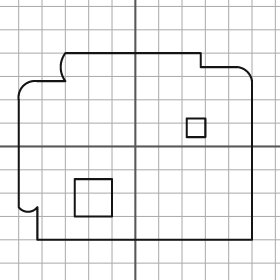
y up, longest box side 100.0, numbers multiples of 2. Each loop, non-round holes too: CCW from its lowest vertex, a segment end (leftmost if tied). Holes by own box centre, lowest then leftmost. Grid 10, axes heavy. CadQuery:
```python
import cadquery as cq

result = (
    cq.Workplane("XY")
    .moveTo(-42.0, -40.0)
    .lineTo(50.0, -40.0)
    .lineTo(50.0, 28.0)
    .threePointArc((48.0, 32.0), (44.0, 34.0))
    .lineTo(28.0, 34.0)
    .lineTo(28.0, 40.0)
    .lineTo(-30.0, 40.0)
    .threePointArc((-32.0, 34.0), (-30.0, 28.0))
    .lineTo(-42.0, 28.0)
    .threePointArc((-48.0, 26.0), (-50.0, 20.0))
    .lineTo(-50.0, -26.0)
    .threePointArc((-46.0, -28.0), (-42.0, -26.0))
    .close()
    .moveTo(-26.0, -30.0)
    .lineTo(-10.0, -30.0)
    .lineTo(-10.0, -14.0)
    .lineTo(-26.0, -14.0)
    .close()
    .moveTo(22.0, 4.0)
    .lineTo(30.0, 4.0)
    .lineTo(30.0, 12.0)
    .lineTo(22.0, 12.0)
    .close()
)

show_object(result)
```